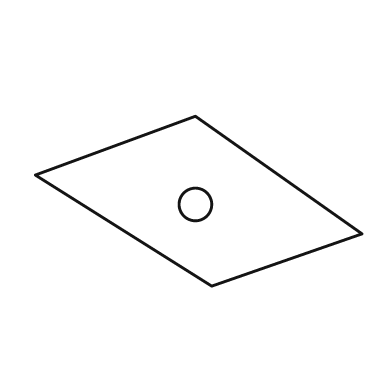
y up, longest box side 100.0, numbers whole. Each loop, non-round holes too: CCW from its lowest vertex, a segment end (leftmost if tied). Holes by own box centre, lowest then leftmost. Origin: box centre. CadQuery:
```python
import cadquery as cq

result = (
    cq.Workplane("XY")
    .moveTo(4.0, -26.0)
    .lineTo(50.0, -10.0)
    .lineTo(-1.0, 26.0)
    .lineTo(-50.0, 8.0)
    .close()
    .moveTo(-1.0, -1.0)
    .circle(5.0)
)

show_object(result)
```